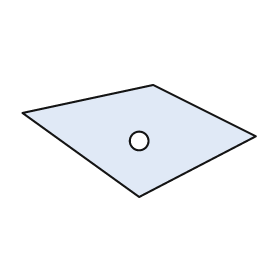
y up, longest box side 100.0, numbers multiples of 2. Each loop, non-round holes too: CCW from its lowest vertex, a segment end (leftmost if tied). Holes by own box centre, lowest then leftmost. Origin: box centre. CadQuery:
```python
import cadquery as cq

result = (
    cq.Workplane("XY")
    .moveTo(0.0, -24.0)
    .lineTo(50.0, 2.0)
    .lineTo(6.0, 24.0)
    .lineTo(-50.0, 12.0)
    .close()
    .moveTo(0.0, 0.0)
    .circle(4.0)
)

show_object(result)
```